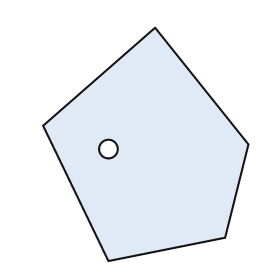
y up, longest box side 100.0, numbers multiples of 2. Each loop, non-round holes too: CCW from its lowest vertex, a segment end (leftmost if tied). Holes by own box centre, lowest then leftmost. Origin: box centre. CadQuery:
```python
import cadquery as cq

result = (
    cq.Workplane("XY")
    .moveTo(-16.0, -50.0)
    .lineTo(34.0, -40.0)
    .lineTo(44.0, 0.0)
    .lineTo(4.0, 50.0)
    .lineTo(-44.0, 8.0)
    .close()
    .moveTo(-16.0, -2.0)
    .circle(4.0)
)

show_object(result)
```